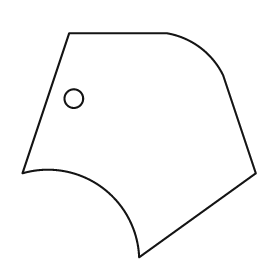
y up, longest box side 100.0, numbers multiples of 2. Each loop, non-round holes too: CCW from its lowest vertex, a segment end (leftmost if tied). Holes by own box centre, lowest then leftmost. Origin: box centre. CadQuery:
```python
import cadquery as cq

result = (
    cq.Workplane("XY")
    .moveTo(0.0, -48.0)
    .lineTo(50.0, -12.0)
    .lineTo(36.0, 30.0)
    .threePointArc((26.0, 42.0), (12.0, 48.0))
    .lineTo(-30.0, 48.0)
    .lineTo(-50.0, -12.0)
    .threePointArc((-16.0, -18.0), (0.0, -48.0))
    .close()
    .moveTo(-28.0, 20.0)
    .circle(4.0)
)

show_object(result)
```